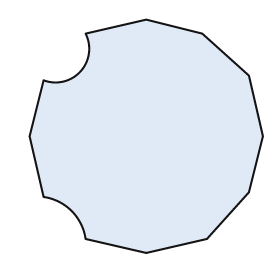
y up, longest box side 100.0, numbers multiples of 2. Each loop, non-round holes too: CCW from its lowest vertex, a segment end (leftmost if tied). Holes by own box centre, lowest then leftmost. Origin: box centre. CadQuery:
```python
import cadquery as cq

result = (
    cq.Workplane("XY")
    .moveTo(0.0, -50.0)
    .lineTo(26.0, -44.0)
    .lineTo(44.0, -24.0)
    .lineTo(50.0, 0.0)
    .lineTo(44.0, 26.0)
    .lineTo(24.0, 44.0)
    .lineTo(0.0, 50.0)
    .lineTo(-26.0, 44.0)
    .threePointArc((-28.0, 28.0), (-44.0, 24.0))
    .lineTo(-50.0, 0.0)
    .lineTo(-44.0, -26.0)
    .threePointArc((-32.0, -32.0), (-26.0, -44.0))
    .close()
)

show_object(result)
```